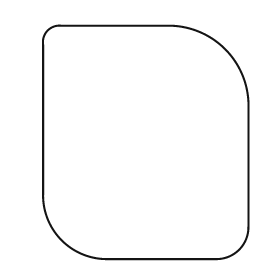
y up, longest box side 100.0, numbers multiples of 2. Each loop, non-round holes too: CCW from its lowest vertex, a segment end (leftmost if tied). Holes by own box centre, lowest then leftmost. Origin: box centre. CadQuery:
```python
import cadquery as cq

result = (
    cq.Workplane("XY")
    .moveTo(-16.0, -50.0)
    .lineTo(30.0, -50.0)
    .threePointArc((40.0, -46.0), (44.0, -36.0))
    .lineTo(44.0, 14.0)
    .threePointArc((34.0, 40.0), (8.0, 50.0))
    .lineTo(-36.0, 50.0)
    .threePointArc((-42.0, 48.0), (-44.0, 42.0))
    .lineTo(-44.0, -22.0)
    .threePointArc((-36.0, -42.0), (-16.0, -50.0))
    .close()
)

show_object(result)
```